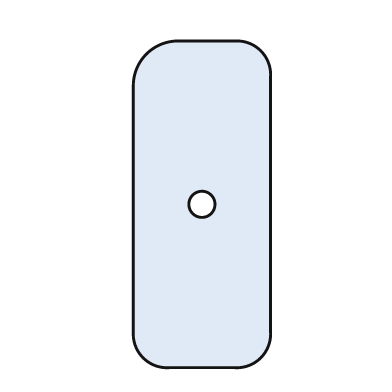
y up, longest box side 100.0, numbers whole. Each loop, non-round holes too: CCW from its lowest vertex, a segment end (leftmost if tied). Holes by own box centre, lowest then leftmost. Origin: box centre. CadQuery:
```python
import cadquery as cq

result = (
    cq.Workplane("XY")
    .moveTo(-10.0, -50.0)
    .lineTo(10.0, -50.0)
    .threePointArc((18.0, -47.0), (21.0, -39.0))
    .lineTo(21.0, 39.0)
    .threePointArc((18.0, 47.0), (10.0, 50.0))
    .lineTo(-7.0, 50.0)
    .threePointArc((-17.0, 46.0), (-21.0, 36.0))
    .lineTo(-21.0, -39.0)
    .threePointArc((-18.0, -47.0), (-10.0, -50.0))
    .close()
    .moveTo(0.0, 0.0)
    .circle(4.0)
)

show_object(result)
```